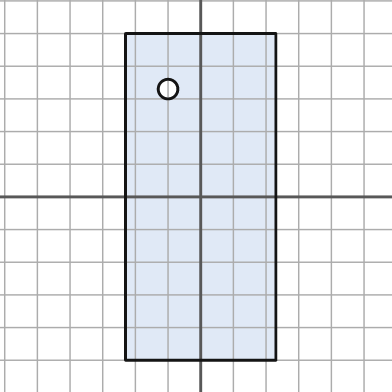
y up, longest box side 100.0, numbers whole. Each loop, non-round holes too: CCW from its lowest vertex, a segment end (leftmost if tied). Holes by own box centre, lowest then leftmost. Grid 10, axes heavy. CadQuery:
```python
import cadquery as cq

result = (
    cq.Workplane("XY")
    .moveTo(-23.0, -50.0)
    .lineTo(23.0, -50.0)
    .lineTo(23.0, 50.0)
    .lineTo(-23.0, 50.0)
    .close()
    .moveTo(-10.0, 33.0)
    .circle(3.0)
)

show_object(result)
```